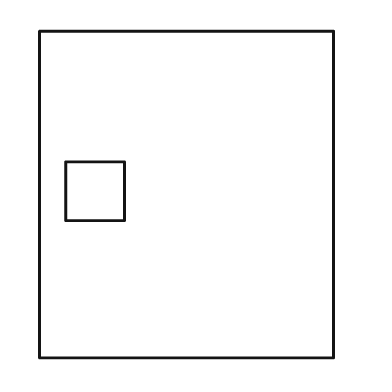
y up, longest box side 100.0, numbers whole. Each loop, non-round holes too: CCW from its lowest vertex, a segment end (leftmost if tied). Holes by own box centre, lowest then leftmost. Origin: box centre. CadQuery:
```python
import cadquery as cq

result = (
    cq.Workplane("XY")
    .moveTo(-45.0, -50.0)
    .lineTo(45.0, -50.0)
    .lineTo(45.0, 50.0)
    .lineTo(-45.0, 50.0)
    .close()
    .moveTo(-37.0, -8.0)
    .lineTo(-19.0, -8.0)
    .lineTo(-19.0, 10.0)
    .lineTo(-37.0, 10.0)
    .close()
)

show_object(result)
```